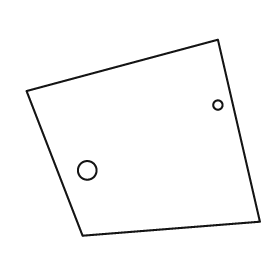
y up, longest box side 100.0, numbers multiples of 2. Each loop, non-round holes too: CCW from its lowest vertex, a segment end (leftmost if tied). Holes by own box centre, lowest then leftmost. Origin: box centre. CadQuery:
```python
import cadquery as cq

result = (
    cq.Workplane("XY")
    .moveTo(-26.0, -42.0)
    .lineTo(50.0, -36.0)
    .lineTo(32.0, 42.0)
    .lineTo(-50.0, 20.0)
    .close()
    .moveTo(-24.0, -14.0)
    .circle(4.0)
    .moveTo(32.0, 14.0)
    .circle(2.0)
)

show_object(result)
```